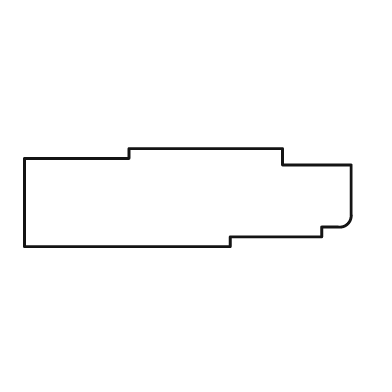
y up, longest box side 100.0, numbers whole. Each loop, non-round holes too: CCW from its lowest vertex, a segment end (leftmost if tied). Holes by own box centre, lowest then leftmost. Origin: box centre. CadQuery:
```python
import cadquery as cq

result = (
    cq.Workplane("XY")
    .moveTo(-50.0, -15.0)
    .lineTo(13.0, -15.0)
    .lineTo(13.0, -12.0)
    .lineTo(41.0, -12.0)
    .lineTo(41.0, -9.0)
    .lineTo(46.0, -9.0)
    .threePointArc((49.0, -8.0), (50.0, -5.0))
    .lineTo(50.0, 10.0)
    .lineTo(29.0, 10.0)
    .lineTo(29.0, 15.0)
    .lineTo(-18.0, 15.0)
    .lineTo(-18.0, 12.0)
    .lineTo(-50.0, 12.0)
    .close()
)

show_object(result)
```